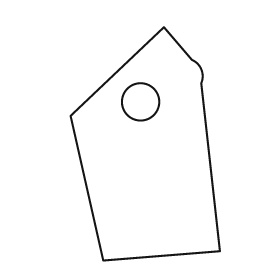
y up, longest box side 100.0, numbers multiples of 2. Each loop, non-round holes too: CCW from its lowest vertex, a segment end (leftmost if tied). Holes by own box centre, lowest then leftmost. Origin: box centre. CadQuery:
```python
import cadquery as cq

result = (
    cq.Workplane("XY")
    .moveTo(-18.0, -50.0)
    .lineTo(32.0, -46.0)
    .lineTo(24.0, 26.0)
    .threePointArc((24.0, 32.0), (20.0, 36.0))
    .lineTo(8.0, 50.0)
    .lineTo(-32.0, 12.0)
    .close()
    .moveTo(-2.0, 18.0)
    .circle(8.0)
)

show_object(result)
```